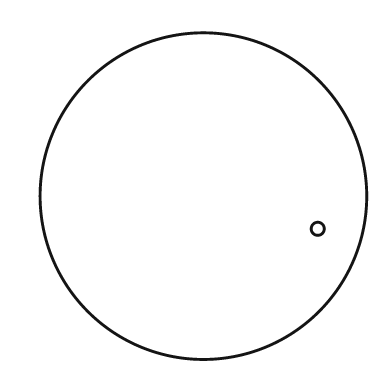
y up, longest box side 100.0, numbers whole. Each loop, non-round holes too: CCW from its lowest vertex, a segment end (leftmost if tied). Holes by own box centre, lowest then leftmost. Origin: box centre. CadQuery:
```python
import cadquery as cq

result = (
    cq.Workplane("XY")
    .moveTo(0.0, 0.0)
    .circle(50.0)
    .moveTo(35.0, -10.0)
    .circle(2.0)
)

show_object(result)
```